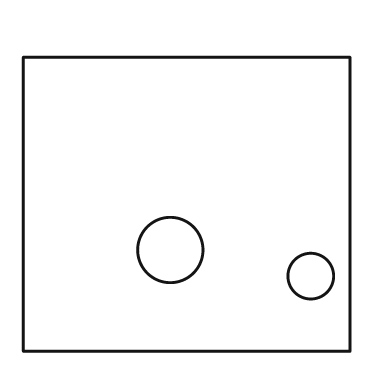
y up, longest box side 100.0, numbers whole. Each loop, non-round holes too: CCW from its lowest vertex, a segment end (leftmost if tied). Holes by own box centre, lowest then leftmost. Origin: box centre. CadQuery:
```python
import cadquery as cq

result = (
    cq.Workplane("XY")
    .moveTo(-50.0, -45.0)
    .lineTo(50.0, -45.0)
    .lineTo(50.0, 45.0)
    .lineTo(-50.0, 45.0)
    .close()
    .moveTo(38.0, -22.0)
    .circle(7.0)
    .moveTo(-5.0, -14.0)
    .circle(10.0)
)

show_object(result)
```